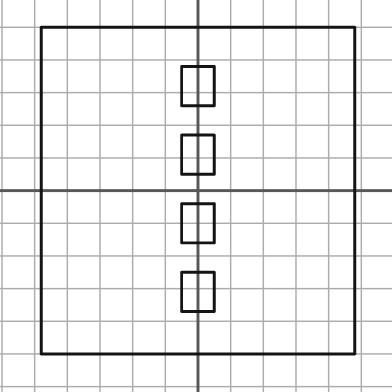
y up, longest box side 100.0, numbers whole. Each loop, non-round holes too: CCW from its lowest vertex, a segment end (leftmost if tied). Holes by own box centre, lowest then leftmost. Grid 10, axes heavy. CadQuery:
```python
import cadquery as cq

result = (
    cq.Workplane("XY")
    .moveTo(-48.0, -50.0)
    .lineTo(48.0, -50.0)
    .lineTo(48.0, 50.0)
    .lineTo(-48.0, 50.0)
    .close()
    .moveTo(-5.0, -37.0)
    .lineTo(5.0, -37.0)
    .lineTo(5.0, -25.0)
    .lineTo(-5.0, -25.0)
    .close()
    .moveTo(-5.0, -16.0)
    .lineTo(5.0, -16.0)
    .lineTo(5.0, -4.0)
    .lineTo(-5.0, -4.0)
    .close()
    .moveTo(-5.0, 5.0)
    .lineTo(5.0, 5.0)
    .lineTo(5.0, 17.0)
    .lineTo(-5.0, 17.0)
    .close()
    .moveTo(-5.0, 26.0)
    .lineTo(5.0, 26.0)
    .lineTo(5.0, 38.0)
    .lineTo(-5.0, 38.0)
    .close()
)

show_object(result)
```